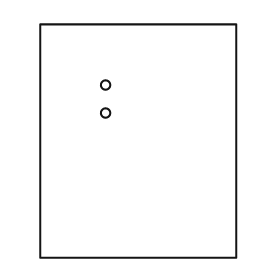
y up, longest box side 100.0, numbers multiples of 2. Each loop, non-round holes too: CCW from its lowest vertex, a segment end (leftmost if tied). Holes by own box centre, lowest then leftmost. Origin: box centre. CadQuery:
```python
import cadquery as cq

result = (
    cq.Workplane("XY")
    .moveTo(-42.0, -50.0)
    .lineTo(42.0, -50.0)
    .lineTo(42.0, 50.0)
    .lineTo(-42.0, 50.0)
    .close()
    .moveTo(-14.0, 12.0)
    .circle(2.0)
    .moveTo(-14.0, 24.0)
    .circle(2.0)
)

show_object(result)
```